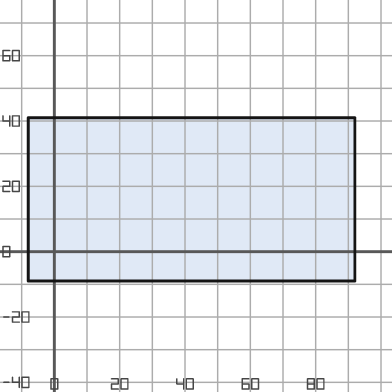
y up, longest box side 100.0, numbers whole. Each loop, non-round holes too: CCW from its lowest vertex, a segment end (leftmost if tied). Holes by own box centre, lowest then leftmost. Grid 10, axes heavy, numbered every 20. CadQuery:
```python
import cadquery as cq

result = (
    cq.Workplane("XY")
    .moveTo(-8.0, -9.0)
    .lineTo(92.0, -9.0)
    .lineTo(92.0, 41.0)
    .lineTo(-8.0, 41.0)
    .close()
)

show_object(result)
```